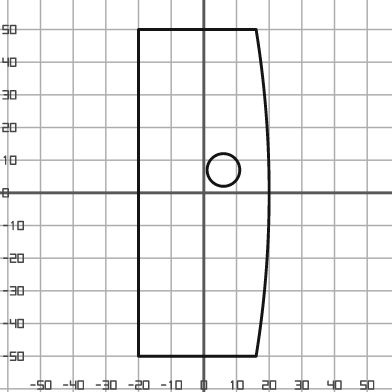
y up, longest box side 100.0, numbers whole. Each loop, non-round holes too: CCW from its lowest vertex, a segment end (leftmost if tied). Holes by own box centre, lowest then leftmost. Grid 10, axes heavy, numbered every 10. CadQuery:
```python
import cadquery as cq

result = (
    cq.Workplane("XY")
    .moveTo(-20.0, -50.0)
    .lineTo(16.0, -50.0)
    .threePointArc((20.0, 0.0), (16.0, 50.0))
    .lineTo(-20.0, 50.0)
    .close()
    .moveTo(6.0, 7.0)
    .circle(5.0)
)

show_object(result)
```